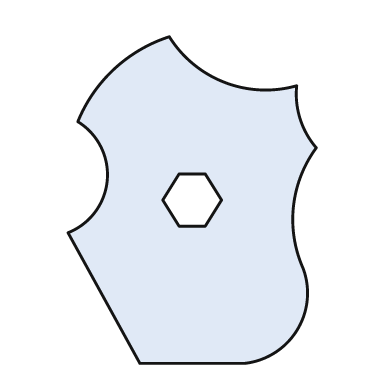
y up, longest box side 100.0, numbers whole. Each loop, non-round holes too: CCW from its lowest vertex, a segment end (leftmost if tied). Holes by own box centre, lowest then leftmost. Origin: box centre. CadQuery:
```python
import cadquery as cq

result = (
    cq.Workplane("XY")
    .moveTo(-16.0, -50.0)
    .lineTo(16.0, -50.0)
    .threePointArc((32.0, -40.0), (34.0, -21.0))
    .threePointArc((31.0, -2.0), (38.0, 16.0))
    .threePointArc((33.0, 25.0), (32.0, 35.0))
    .threePointArc((10.0, 36.0), (-7.0, 50.0))
    .threePointArc((-24.0, 40.0), (-35.0, 24.0))
    .threePointArc((-26.0, 6.0), (-38.0, -10.0))
    .close()
    .moveTo(-4.0, -8.0)
    .lineTo(4.0, -8.0)
    .lineTo(9.0, 0.0)
    .lineTo(4.0, 8.0)
    .lineTo(-4.0, 8.0)
    .lineTo(-9.0, 0.0)
    .close()
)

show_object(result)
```